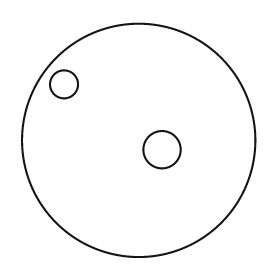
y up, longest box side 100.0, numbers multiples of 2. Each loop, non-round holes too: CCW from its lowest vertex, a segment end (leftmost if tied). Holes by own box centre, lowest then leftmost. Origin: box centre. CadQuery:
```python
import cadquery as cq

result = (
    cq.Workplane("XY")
    .moveTo(0.0, 0.0)
    .circle(50.0)
    .moveTo(10.0, -4.0)
    .circle(8.0)
    .moveTo(-32.0, 24.0)
    .circle(6.0)
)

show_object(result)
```